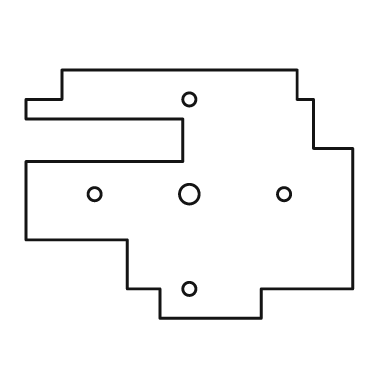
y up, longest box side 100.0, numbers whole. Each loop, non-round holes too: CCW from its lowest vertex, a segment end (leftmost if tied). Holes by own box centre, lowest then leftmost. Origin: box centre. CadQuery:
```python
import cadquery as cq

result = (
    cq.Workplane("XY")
    .moveTo(-9.0, -38.0)
    .lineTo(22.0, -38.0)
    .lineTo(22.0, -29.0)
    .lineTo(50.0, -29.0)
    .lineTo(50.0, 14.0)
    .lineTo(38.0, 14.0)
    .lineTo(38.0, 29.0)
    .lineTo(33.0, 29.0)
    .lineTo(33.0, 38.0)
    .lineTo(-39.0, 38.0)
    .lineTo(-39.0, 29.0)
    .lineTo(-50.0, 29.0)
    .lineTo(-50.0, 23.0)
    .lineTo(-2.0, 23.0)
    .lineTo(-2.0, 10.0)
    .lineTo(-50.0, 10.0)
    .lineTo(-50.0, -14.0)
    .lineTo(-19.0, -14.0)
    .lineTo(-19.0, -29.0)
    .lineTo(-9.0, -29.0)
    .close()
    .moveTo(0.0, -29.0)
    .circle(2.0)
    .moveTo(-29.0, 0.0)
    .circle(2.0)
    .moveTo(0.0, 0.0)
    .circle(3.0)
    .moveTo(29.0, 0.0)
    .circle(2.0)
    .moveTo(0.0, 29.0)
    .circle(2.0)
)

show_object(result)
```